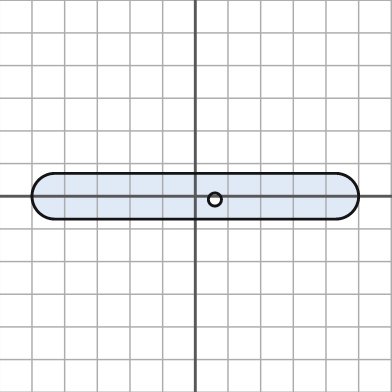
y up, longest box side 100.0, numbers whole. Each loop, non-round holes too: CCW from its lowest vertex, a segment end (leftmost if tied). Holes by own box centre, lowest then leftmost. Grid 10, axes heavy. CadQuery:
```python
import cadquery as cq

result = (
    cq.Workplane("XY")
    .moveTo(-43.0, -7.0)
    .lineTo(43.0, -7.0)
    .threePointArc((50.0, 0.0), (43.0, 7.0))
    .lineTo(-43.0, 7.0)
    .threePointArc((-50.0, 0.0), (-43.0, -7.0))
    .close()
    .moveTo(6.0, -1.0)
    .circle(2.0)
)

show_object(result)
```